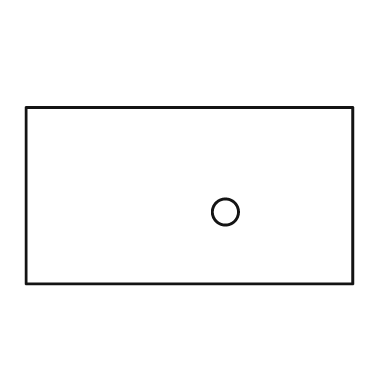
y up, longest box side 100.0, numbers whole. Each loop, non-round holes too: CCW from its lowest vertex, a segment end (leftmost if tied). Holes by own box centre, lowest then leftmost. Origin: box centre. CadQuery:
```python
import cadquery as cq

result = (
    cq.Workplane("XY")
    .moveTo(-50.0, -27.0)
    .lineTo(50.0, -27.0)
    .lineTo(50.0, 27.0)
    .lineTo(-50.0, 27.0)
    .close()
    .moveTo(11.0, -5.0)
    .circle(4.0)
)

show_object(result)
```